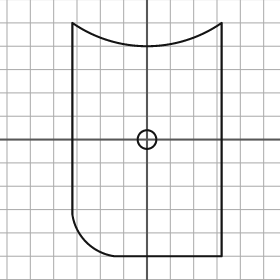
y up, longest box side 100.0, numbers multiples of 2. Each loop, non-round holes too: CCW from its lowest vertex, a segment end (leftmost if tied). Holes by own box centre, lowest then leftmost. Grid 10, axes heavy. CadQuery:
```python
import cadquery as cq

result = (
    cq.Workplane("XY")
    .moveTo(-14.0, -50.0)
    .lineTo(32.0, -50.0)
    .lineTo(32.0, 50.0)
    .threePointArc((0.0, 40.0), (-32.0, 50.0))
    .lineTo(-32.0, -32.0)
    .threePointArc((-26.0, -44.0), (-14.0, -50.0))
    .close()
    .moveTo(0.0, 0.0)
    .circle(4.0)
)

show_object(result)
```